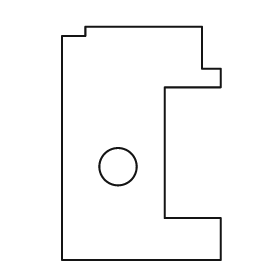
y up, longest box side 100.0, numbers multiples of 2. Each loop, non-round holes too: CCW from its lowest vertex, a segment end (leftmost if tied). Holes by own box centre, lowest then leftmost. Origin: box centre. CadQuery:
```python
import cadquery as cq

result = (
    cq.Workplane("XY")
    .moveTo(-34.0, -50.0)
    .lineTo(34.0, -50.0)
    .lineTo(34.0, -32.0)
    .lineTo(10.0, -32.0)
    .lineTo(10.0, 24.0)
    .lineTo(34.0, 24.0)
    .lineTo(34.0, 32.0)
    .lineTo(26.0, 32.0)
    .lineTo(26.0, 50.0)
    .lineTo(-24.0, 50.0)
    .lineTo(-24.0, 46.0)
    .lineTo(-34.0, 46.0)
    .close()
    .moveTo(-10.0, -10.0)
    .circle(8.0)
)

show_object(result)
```